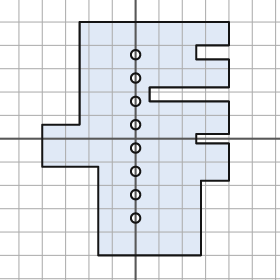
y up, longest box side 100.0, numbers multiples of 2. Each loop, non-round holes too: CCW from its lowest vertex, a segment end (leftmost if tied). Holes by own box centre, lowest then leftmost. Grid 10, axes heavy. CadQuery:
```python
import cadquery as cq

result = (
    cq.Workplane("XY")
    .moveTo(-16.0, -50.0)
    .lineTo(28.0, -50.0)
    .lineTo(28.0, -18.0)
    .lineTo(40.0, -18.0)
    .lineTo(40.0, -2.0)
    .lineTo(26.0, -2.0)
    .lineTo(26.0, 2.0)
    .lineTo(40.0, 2.0)
    .lineTo(40.0, 16.0)
    .lineTo(6.0, 16.0)
    .lineTo(6.0, 22.0)
    .lineTo(40.0, 22.0)
    .lineTo(40.0, 34.0)
    .lineTo(26.0, 34.0)
    .lineTo(26.0, 40.0)
    .lineTo(40.0, 40.0)
    .lineTo(40.0, 50.0)
    .lineTo(-24.0, 50.0)
    .lineTo(-24.0, 6.0)
    .lineTo(-40.0, 6.0)
    .lineTo(-40.0, -12.0)
    .lineTo(-16.0, -12.0)
    .close()
    .moveTo(0.0, -34.0)
    .circle(2.0)
    .moveTo(0.0, -24.0)
    .circle(2.0)
    .moveTo(0.0, -14.0)
    .circle(2.0)
    .moveTo(0.0, -4.0)
    .circle(2.0)
    .moveTo(0.0, 6.0)
    .circle(2.0)
    .moveTo(0.0, 16.0)
    .circle(2.0)
    .moveTo(0.0, 26.0)
    .circle(2.0)
    .moveTo(0.0, 36.0)
    .circle(2.0)
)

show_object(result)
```